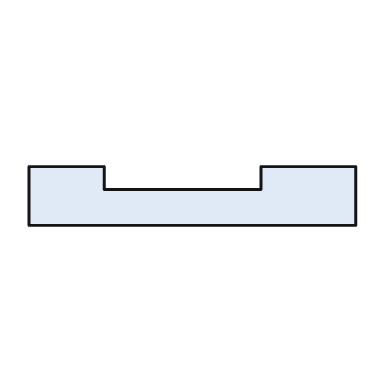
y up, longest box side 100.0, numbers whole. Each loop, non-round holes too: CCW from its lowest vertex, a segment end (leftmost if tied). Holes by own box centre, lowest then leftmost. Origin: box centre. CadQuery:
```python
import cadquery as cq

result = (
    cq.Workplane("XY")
    .moveTo(-50.0, -9.0)
    .lineTo(50.0, -9.0)
    .lineTo(50.0, 9.0)
    .lineTo(21.0, 9.0)
    .lineTo(21.0, 2.0)
    .lineTo(-27.0, 2.0)
    .lineTo(-27.0, 9.0)
    .lineTo(-50.0, 9.0)
    .close()
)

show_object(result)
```